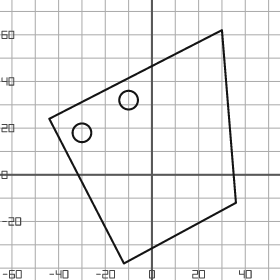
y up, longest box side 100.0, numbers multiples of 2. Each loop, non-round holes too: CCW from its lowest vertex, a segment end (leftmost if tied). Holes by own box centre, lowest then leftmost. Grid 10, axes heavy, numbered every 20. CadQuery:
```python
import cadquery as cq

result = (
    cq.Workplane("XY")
    .moveTo(-12.0, -38.0)
    .lineTo(36.0, -12.0)
    .lineTo(30.0, 62.0)
    .lineTo(-44.0, 24.0)
    .close()
    .moveTo(-30.0, 18.0)
    .circle(4.0)
    .moveTo(-10.0, 32.0)
    .circle(4.0)
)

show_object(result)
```